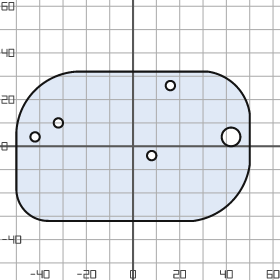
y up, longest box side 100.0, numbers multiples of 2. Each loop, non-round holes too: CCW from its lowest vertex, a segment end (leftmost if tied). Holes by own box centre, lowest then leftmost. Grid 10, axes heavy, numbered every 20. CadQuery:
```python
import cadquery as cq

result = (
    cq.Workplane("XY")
    .moveTo(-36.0, -32.0)
    .lineTo(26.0, -32.0)
    .threePointArc((42.0, -24.0), (50.0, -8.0))
    .lineTo(50.0, 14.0)
    .threePointArc((44.0, 26.0), (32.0, 32.0))
    .lineTo(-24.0, 32.0)
    .threePointArc((-42.0, 24.0), (-50.0, 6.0))
    .lineTo(-50.0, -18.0)
    .threePointArc((-46.0, -28.0), (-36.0, -32.0))
    .close()
    .moveTo(8.0, -4.0)
    .circle(2.0)
    .moveTo(-42.0, 4.0)
    .circle(2.0)
    .moveTo(42.0, 4.0)
    .circle(4.0)
    .moveTo(-32.0, 10.0)
    .circle(2.0)
    .moveTo(16.0, 26.0)
    .circle(2.0)
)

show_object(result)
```